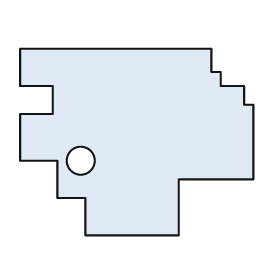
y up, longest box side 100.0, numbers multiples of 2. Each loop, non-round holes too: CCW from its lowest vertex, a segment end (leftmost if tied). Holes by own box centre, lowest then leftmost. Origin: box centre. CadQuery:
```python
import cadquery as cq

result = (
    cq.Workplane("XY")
    .moveTo(-22.0, -40.0)
    .lineTo(18.0, -40.0)
    .lineTo(18.0, -16.0)
    .lineTo(50.0, -16.0)
    .lineTo(50.0, 16.0)
    .lineTo(46.0, 16.0)
    .lineTo(46.0, 24.0)
    .lineTo(36.0, 24.0)
    .lineTo(36.0, 30.0)
    .lineTo(32.0, 30.0)
    .lineTo(32.0, 40.0)
    .lineTo(-50.0, 40.0)
    .lineTo(-50.0, 24.0)
    .lineTo(-36.0, 24.0)
    .lineTo(-36.0, 12.0)
    .lineTo(-50.0, 12.0)
    .lineTo(-50.0, -8.0)
    .lineTo(-34.0, -8.0)
    .lineTo(-34.0, -24.0)
    .lineTo(-22.0, -24.0)
    .close()
    .moveTo(-24.0, -8.0)
    .circle(6.0)
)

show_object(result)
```